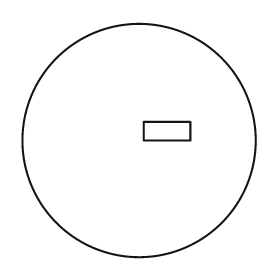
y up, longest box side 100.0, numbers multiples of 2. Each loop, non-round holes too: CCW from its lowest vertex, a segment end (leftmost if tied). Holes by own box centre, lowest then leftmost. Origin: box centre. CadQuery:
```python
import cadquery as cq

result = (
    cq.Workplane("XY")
    .moveTo(0.0, 0.0)
    .circle(50.0)
    .moveTo(2.0, 0.0)
    .lineTo(22.0, 0.0)
    .lineTo(22.0, 8.0)
    .lineTo(2.0, 8.0)
    .close()
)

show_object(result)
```